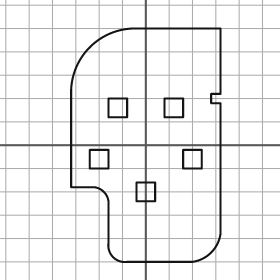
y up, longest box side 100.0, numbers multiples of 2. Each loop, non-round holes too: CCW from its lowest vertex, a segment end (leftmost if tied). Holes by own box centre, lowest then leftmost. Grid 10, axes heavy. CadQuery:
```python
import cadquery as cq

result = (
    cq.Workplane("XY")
    .moveTo(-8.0, -50.0)
    .lineTo(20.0, -50.0)
    .threePointArc((28.0, -46.0), (32.0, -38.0))
    .lineTo(32.0, 18.0)
    .lineTo(28.0, 18.0)
    .lineTo(28.0, 22.0)
    .lineTo(32.0, 22.0)
    .lineTo(32.0, 50.0)
    .lineTo(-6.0, 50.0)
    .threePointArc((-24.0, 42.0), (-32.0, 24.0))
    .lineTo(-32.0, -18.0)
    .lineTo(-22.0, -18.0)
    .threePointArc((-18.0, -20.0), (-16.0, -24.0))
    .lineTo(-16.0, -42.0)
    .threePointArc((-14.0, -48.0), (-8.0, -50.0))
    .close()
    .moveTo(-4.0, -24.0)
    .lineTo(4.0, -24.0)
    .lineTo(4.0, -16.0)
    .lineTo(-4.0, -16.0)
    .close()
    .moveTo(-24.0, -10.0)
    .lineTo(-16.0, -10.0)
    .lineTo(-16.0, -2.0)
    .lineTo(-24.0, -2.0)
    .close()
    .moveTo(16.0, -10.0)
    .lineTo(24.0, -10.0)
    .lineTo(24.0, -2.0)
    .lineTo(16.0, -2.0)
    .close()
    .moveTo(-16.0, 12.0)
    .lineTo(-8.0, 12.0)
    .lineTo(-8.0, 20.0)
    .lineTo(-16.0, 20.0)
    .close()
    .moveTo(8.0, 12.0)
    .lineTo(16.0, 12.0)
    .lineTo(16.0, 20.0)
    .lineTo(8.0, 20.0)
    .close()
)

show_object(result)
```